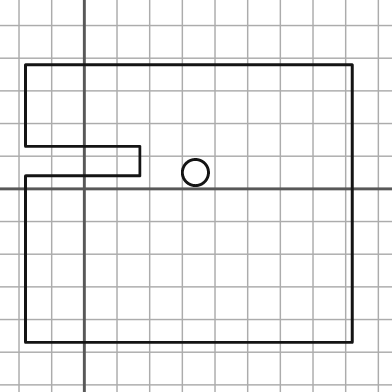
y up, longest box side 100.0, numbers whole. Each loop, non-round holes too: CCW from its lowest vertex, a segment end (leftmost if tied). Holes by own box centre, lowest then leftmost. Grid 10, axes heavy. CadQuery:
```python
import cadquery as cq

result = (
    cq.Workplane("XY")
    .moveTo(-18.0, -47.0)
    .lineTo(82.0, -47.0)
    .lineTo(82.0, 38.0)
    .lineTo(-18.0, 38.0)
    .lineTo(-18.0, 13.0)
    .lineTo(17.0, 13.0)
    .lineTo(17.0, 4.0)
    .lineTo(-18.0, 4.0)
    .close()
    .moveTo(34.0, 5.0)
    .circle(4.0)
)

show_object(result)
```